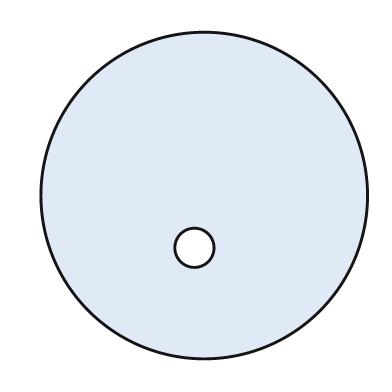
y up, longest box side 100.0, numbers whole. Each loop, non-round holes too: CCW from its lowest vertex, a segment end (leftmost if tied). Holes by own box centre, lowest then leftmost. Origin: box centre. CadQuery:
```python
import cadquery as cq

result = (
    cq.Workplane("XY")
    .moveTo(0.0, 0.0)
    .circle(50.0)
    .moveTo(-3.0, -16.0)
    .circle(6.0)
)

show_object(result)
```